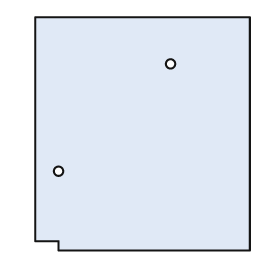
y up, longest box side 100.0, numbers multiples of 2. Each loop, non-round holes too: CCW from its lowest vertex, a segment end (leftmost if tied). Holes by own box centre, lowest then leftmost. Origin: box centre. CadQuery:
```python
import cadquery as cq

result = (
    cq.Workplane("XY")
    .moveTo(-36.0, -50.0)
    .lineTo(46.0, -50.0)
    .lineTo(46.0, 50.0)
    .lineTo(-46.0, 50.0)
    .lineTo(-46.0, -46.0)
    .lineTo(-36.0, -46.0)
    .close()
    .moveTo(-36.0, -16.0)
    .circle(2.0)
    .moveTo(12.0, 30.0)
    .circle(2.0)
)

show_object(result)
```